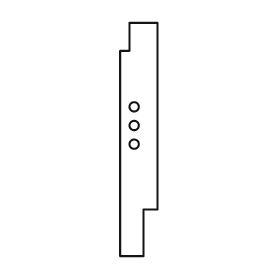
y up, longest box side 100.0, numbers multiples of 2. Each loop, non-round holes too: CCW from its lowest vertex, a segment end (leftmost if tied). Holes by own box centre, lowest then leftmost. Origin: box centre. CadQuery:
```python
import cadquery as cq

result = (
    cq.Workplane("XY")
    .moveTo(-8.0, -50.0)
    .lineTo(2.0, -50.0)
    .lineTo(2.0, -30.0)
    .lineTo(8.0, -30.0)
    .lineTo(8.0, 50.0)
    .lineTo(-4.0, 50.0)
    .lineTo(-4.0, 38.0)
    .lineTo(-8.0, 38.0)
    .close()
    .moveTo(-2.0, -2.0)
    .circle(2.0)
    .moveTo(-2.0, 6.0)
    .circle(2.0)
    .moveTo(-2.0, 14.0)
    .circle(2.0)
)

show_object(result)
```